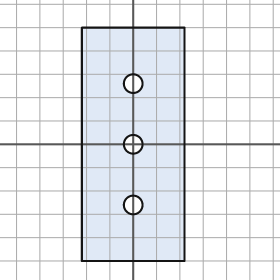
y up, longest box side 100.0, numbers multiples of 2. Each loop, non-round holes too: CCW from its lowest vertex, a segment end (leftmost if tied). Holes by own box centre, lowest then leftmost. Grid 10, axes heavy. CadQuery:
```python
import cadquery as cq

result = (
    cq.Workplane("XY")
    .moveTo(-22.0, -50.0)
    .lineTo(22.0, -50.0)
    .lineTo(22.0, 50.0)
    .lineTo(-22.0, 50.0)
    .close()
    .moveTo(0.0, -26.0)
    .circle(4.0)
    .moveTo(0.0, 0.0)
    .circle(4.0)
    .moveTo(0.0, 26.0)
    .circle(4.0)
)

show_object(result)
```